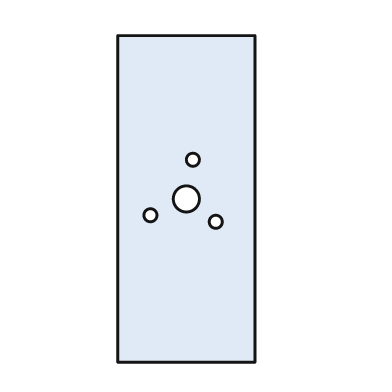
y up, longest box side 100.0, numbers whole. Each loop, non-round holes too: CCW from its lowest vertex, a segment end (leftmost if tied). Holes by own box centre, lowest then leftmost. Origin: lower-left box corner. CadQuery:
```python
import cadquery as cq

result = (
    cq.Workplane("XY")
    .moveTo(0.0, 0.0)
    .lineTo(42.0, 0.0)
    .lineTo(42.0, 100.0)
    .lineTo(0.0, 100.0)
    .close()
    .moveTo(30.0, 43.0)
    .circle(2.0)
    .moveTo(10.0, 45.0)
    .circle(2.0)
    .moveTo(21.0, 50.0)
    .circle(4.0)
    .moveTo(23.0, 62.0)
    .circle(2.0)
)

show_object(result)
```